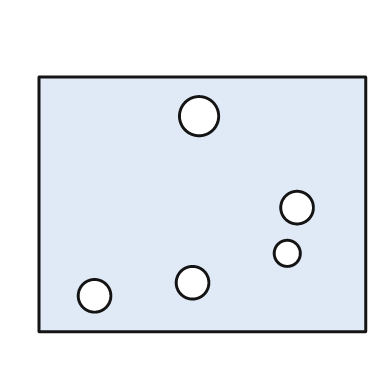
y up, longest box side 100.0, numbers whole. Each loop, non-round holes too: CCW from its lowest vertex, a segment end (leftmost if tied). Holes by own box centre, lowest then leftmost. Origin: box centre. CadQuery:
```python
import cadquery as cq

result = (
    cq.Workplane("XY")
    .moveTo(-50.0, -39.0)
    .lineTo(50.0, -39.0)
    .lineTo(50.0, 39.0)
    .lineTo(-50.0, 39.0)
    .close()
    .moveTo(-33.0, -28.0)
    .circle(5.0)
    .moveTo(-3.0, -24.0)
    .circle(5.0)
    .moveTo(26.0, -15.0)
    .circle(4.0)
    .moveTo(29.0, -1.0)
    .circle(5.0)
    .moveTo(-1.0, 27.0)
    .circle(6.0)
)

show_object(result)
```